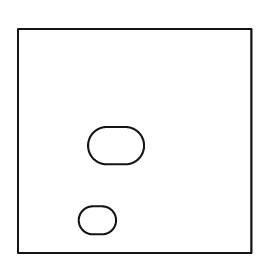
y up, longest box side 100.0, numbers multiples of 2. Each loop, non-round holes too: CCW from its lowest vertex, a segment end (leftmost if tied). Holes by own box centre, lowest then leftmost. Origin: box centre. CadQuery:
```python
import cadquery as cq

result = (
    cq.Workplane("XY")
    .moveTo(-50.0, -48.0)
    .lineTo(50.0, -48.0)
    .lineTo(50.0, 48.0)
    .lineTo(-50.0, 48.0)
    .close()
    .moveTo(-18.0, -40.0)
    .lineTo(-14.0, -40.0)
    .threePointArc((-8.0, -34.0), (-14.0, -28.0))
    .lineTo(-18.0, -28.0)
    .threePointArc((-24.0, -34.0), (-18.0, -40.0))
    .close()
    .moveTo(-12.0, -10.0)
    .lineTo(-4.0, -10.0)
    .threePointArc((4.0, -2.0), (-4.0, 6.0))
    .lineTo(-12.0, 6.0)
    .threePointArc((-20.0, -2.0), (-12.0, -10.0))
    .close()
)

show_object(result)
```